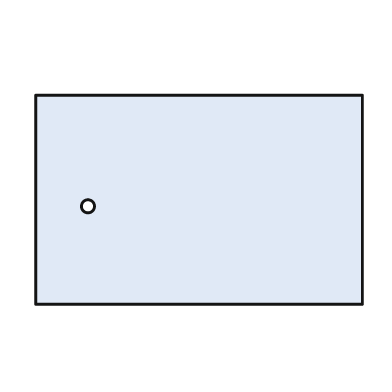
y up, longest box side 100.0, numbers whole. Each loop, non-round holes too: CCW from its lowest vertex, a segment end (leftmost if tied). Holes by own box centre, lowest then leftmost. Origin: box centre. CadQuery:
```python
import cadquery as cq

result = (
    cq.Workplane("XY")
    .moveTo(-50.0, -32.0)
    .lineTo(50.0, -32.0)
    .lineTo(50.0, 32.0)
    .lineTo(-50.0, 32.0)
    .close()
    .moveTo(-34.0, -2.0)
    .circle(2.0)
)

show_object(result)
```